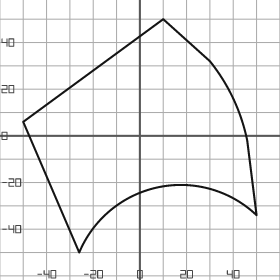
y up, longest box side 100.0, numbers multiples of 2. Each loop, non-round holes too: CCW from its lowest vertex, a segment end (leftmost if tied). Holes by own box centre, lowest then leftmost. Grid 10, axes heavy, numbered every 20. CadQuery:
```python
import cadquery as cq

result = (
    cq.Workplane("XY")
    .moveTo(-26.0, -50.0)
    .threePointArc((8.0, -22.0), (50.0, -34.0))
    .lineTo(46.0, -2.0)
    .threePointArc((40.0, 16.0), (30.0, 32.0))
    .lineTo(10.0, 50.0)
    .lineTo(-50.0, 6.0)
    .close()
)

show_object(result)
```